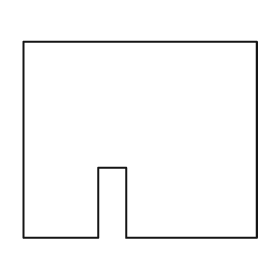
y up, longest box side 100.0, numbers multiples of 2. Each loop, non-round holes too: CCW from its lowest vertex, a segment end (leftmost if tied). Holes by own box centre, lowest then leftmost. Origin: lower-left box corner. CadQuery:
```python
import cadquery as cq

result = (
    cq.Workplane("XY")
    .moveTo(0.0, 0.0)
    .lineTo(32.0, 0.0)
    .lineTo(32.0, 30.0)
    .lineTo(44.0, 30.0)
    .lineTo(44.0, 0.0)
    .lineTo(100.0, 0.0)
    .lineTo(100.0, 84.0)
    .lineTo(0.0, 84.0)
    .close()
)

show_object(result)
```